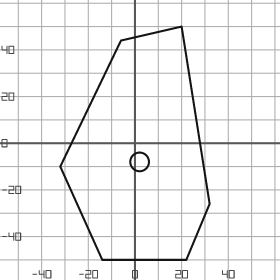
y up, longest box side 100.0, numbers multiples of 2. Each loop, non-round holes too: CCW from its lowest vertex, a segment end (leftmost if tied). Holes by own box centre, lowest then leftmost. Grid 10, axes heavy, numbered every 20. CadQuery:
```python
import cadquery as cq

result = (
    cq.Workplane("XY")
    .moveTo(-14.0, -50.0)
    .lineTo(22.0, -50.0)
    .lineTo(32.0, -26.0)
    .lineTo(20.0, 50.0)
    .lineTo(-6.0, 44.0)
    .lineTo(-32.0, -10.0)
    .close()
    .moveTo(2.0, -8.0)
    .circle(4.0)
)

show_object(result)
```